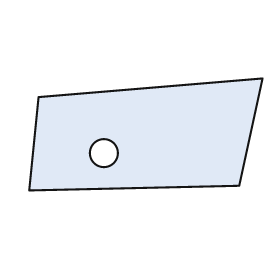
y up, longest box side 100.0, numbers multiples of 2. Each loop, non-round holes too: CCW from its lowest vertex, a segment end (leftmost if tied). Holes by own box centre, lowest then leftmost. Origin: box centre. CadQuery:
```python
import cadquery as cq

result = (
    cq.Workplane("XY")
    .moveTo(-50.0, -24.0)
    .lineTo(40.0, -22.0)
    .lineTo(50.0, 24.0)
    .lineTo(-46.0, 16.0)
    .close()
    .moveTo(-18.0, -8.0)
    .circle(6.0)
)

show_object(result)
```